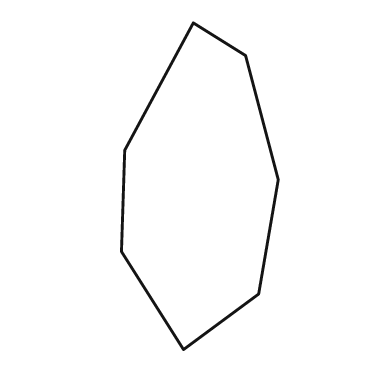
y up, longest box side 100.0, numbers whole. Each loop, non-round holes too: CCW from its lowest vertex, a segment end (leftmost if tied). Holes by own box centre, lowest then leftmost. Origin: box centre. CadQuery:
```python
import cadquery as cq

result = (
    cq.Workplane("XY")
    .moveTo(-5.0, -50.0)
    .lineTo(18.0, -33.0)
    .lineTo(24.0, 2.0)
    .lineTo(14.0, 40.0)
    .lineTo(-2.0, 50.0)
    .lineTo(-23.0, 11.0)
    .lineTo(-24.0, -20.0)
    .close()
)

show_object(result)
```